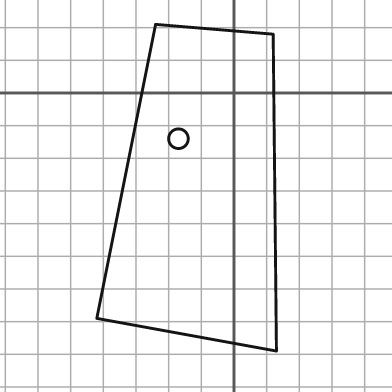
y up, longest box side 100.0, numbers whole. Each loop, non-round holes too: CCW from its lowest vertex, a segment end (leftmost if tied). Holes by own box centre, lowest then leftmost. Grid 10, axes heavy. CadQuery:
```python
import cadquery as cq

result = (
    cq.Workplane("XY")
    .moveTo(13.0, -79.0)
    .lineTo(12.0, 18.0)
    .lineTo(-24.0, 21.0)
    .lineTo(-42.0, -69.0)
    .close()
    .moveTo(-17.0, -14.0)
    .circle(3.0)
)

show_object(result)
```